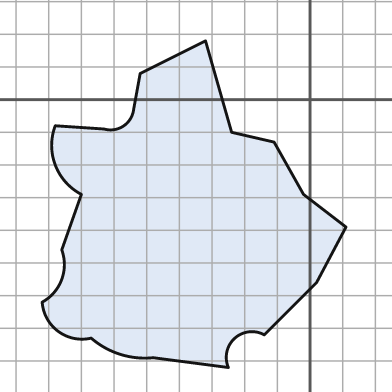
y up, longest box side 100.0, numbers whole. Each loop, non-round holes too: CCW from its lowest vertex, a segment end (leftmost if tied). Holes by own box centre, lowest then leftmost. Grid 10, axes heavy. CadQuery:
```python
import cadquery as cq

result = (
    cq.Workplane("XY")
    .moveTo(-25.0, -82.0)
    .threePointArc((-23.0, -73.0), (-14.0, -72.0))
    .lineTo(2.0, -56.0)
    .lineTo(11.0, -39.0)
    .lineTo(-2.0, -29.0)
    .lineTo(-11.0, -13.0)
    .lineTo(-24.0, -10.0)
    .lineTo(-32.0, 18.0)
    .lineTo(-52.0, 8.0)
    .lineTo(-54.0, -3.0)
    .threePointArc((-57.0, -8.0), (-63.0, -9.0))
    .lineTo(-78.0, -8.0)
    .threePointArc((-78.0, -20.0), (-70.0, -29.0))
    .lineTo(-76.0, -46.0)
    .threePointArc((-76.0, -55.0), (-82.0, -62.0))
    .threePointArc((-77.0, -71.0), (-67.0, -73.0))
    .threePointArc((-58.0, -78.0), (-48.0, -79.0))
    .close()
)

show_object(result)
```